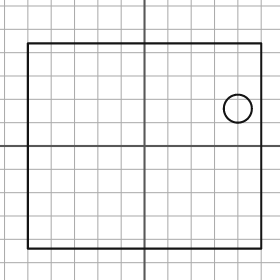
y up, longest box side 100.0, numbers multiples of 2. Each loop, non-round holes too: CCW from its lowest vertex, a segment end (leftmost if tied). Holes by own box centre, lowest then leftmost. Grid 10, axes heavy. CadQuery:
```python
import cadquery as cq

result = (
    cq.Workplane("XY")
    .moveTo(-50.0, -44.0)
    .lineTo(50.0, -44.0)
    .lineTo(50.0, 44.0)
    .lineTo(-50.0, 44.0)
    .close()
    .moveTo(40.0, 16.0)
    .circle(6.0)
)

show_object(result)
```